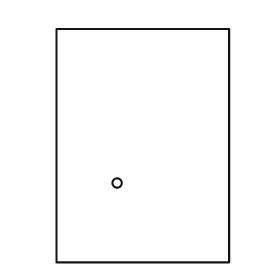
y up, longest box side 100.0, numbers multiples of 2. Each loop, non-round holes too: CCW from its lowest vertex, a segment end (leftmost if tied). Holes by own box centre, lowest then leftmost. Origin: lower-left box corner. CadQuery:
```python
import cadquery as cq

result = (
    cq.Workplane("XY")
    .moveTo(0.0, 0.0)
    .lineTo(74.0, 0.0)
    .lineTo(74.0, 100.0)
    .lineTo(0.0, 100.0)
    .close()
    .moveTo(26.0, 34.0)
    .circle(2.0)
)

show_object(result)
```